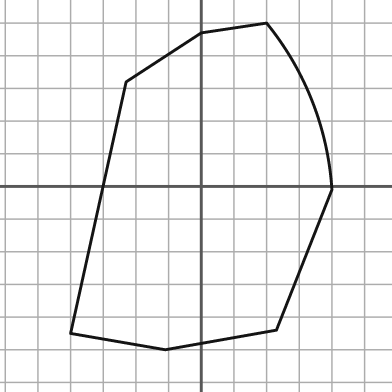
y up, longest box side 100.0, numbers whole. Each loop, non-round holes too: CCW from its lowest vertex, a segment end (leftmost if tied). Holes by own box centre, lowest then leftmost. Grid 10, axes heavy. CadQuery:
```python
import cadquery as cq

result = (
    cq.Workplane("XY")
    .moveTo(-11.0, -50.0)
    .lineTo(23.0, -44.0)
    .lineTo(40.0, -1.0)
    .threePointArc((34.0, 26.0), (20.0, 50.0))
    .lineTo(0.0, 47.0)
    .lineTo(-23.0, 32.0)
    .lineTo(-40.0, -45.0)
    .close()
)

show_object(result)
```